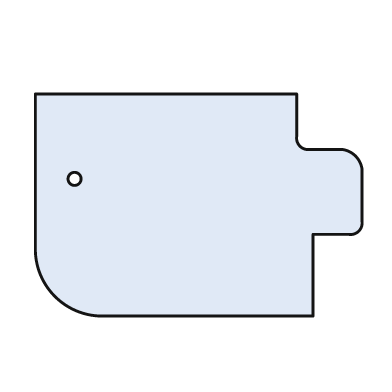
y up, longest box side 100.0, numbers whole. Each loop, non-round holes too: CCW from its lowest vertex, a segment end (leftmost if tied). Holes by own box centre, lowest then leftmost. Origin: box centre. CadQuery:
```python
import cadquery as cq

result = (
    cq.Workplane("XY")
    .moveTo(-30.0, -34.0)
    .lineTo(35.0, -34.0)
    .lineTo(35.0, -9.0)
    .lineTo(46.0, -9.0)
    .threePointArc((49.0, -8.0), (50.0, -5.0))
    .lineTo(50.0, 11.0)
    .threePointArc((48.0, 15.0), (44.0, 17.0))
    .lineTo(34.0, 17.0)
    .threePointArc((31.0, 18.0), (30.0, 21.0))
    .lineTo(30.0, 34.0)
    .lineTo(-50.0, 34.0)
    .lineTo(-50.0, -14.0)
    .threePointArc((-44.0, -28.0), (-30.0, -34.0))
    .close()
    .moveTo(-38.0, 8.0)
    .circle(2.0)
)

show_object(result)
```